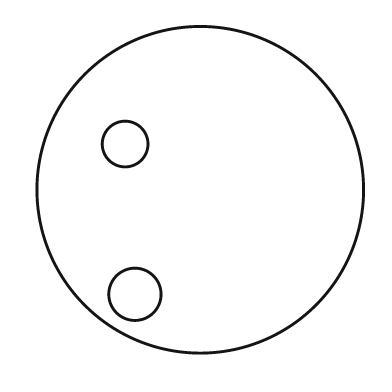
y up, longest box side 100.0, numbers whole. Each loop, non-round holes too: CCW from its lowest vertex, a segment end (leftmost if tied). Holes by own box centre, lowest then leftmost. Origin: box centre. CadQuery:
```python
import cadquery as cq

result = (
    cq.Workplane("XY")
    .moveTo(0.0, 0.0)
    .circle(50.0)
    .moveTo(-20.0, -32.0)
    .circle(8.0)
    .moveTo(-23.0, 14.0)
    .circle(7.0)
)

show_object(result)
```